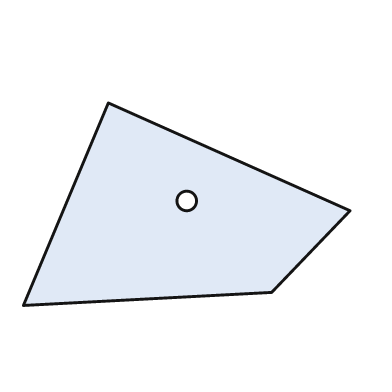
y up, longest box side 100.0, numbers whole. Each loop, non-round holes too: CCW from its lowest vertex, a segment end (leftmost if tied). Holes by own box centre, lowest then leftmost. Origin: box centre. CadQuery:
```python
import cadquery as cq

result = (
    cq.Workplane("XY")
    .moveTo(-50.0, -31.0)
    .lineTo(26.0, -27.0)
    .lineTo(50.0, -2.0)
    .lineTo(-24.0, 31.0)
    .close()
    .moveTo(0.0, 1.0)
    .circle(3.0)
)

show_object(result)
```